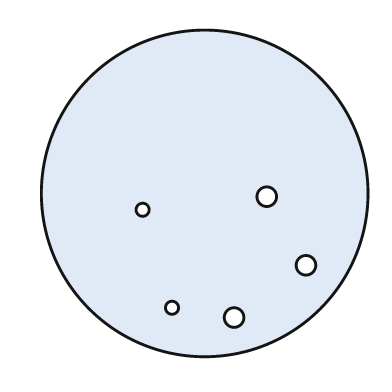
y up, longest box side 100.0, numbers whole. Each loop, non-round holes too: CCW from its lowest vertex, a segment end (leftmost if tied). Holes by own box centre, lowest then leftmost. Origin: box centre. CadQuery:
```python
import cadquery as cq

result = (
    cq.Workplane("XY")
    .moveTo(0.0, 0.0)
    .circle(50.0)
    .moveTo(9.0, -38.0)
    .circle(3.0)
    .moveTo(-10.0, -35.0)
    .circle(2.0)
    .moveTo(31.0, -22.0)
    .circle(3.0)
    .moveTo(-19.0, -5.0)
    .circle(2.0)
    .moveTo(19.0, -1.0)
    .circle(3.0)
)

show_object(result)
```